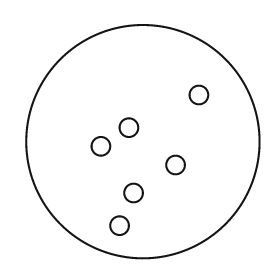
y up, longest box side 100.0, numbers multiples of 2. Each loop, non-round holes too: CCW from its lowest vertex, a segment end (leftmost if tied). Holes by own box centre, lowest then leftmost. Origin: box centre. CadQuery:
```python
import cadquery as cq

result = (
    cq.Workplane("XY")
    .moveTo(0.0, 0.0)
    .circle(50.0)
    .moveTo(-10.0, -36.0)
    .circle(4.0)
    .moveTo(-4.0, -22.0)
    .circle(4.0)
    .moveTo(14.0, -10.0)
    .circle(4.0)
    .moveTo(-18.0, -2.0)
    .circle(4.0)
    .moveTo(-6.0, 6.0)
    .circle(4.0)
    .moveTo(24.0, 20.0)
    .circle(4.0)
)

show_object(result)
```